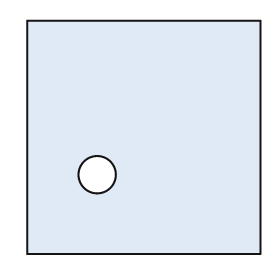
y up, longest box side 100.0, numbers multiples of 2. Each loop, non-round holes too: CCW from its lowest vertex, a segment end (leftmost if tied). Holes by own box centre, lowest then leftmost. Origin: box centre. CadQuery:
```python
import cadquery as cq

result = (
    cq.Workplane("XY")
    .moveTo(-50.0, -50.0)
    .lineTo(50.0, -50.0)
    .lineTo(50.0, 50.0)
    .lineTo(-50.0, 50.0)
    .close()
    .moveTo(-20.0, -16.0)
    .circle(8.0)
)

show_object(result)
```